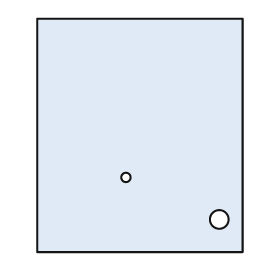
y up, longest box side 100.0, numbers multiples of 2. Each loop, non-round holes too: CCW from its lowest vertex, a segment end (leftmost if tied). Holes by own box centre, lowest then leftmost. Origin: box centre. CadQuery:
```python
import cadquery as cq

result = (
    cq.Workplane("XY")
    .moveTo(-44.0, -50.0)
    .lineTo(44.0, -50.0)
    .lineTo(44.0, 50.0)
    .lineTo(-44.0, 50.0)
    .close()
    .moveTo(34.0, -36.0)
    .circle(4.0)
    .moveTo(-6.0, -18.0)
    .circle(2.0)
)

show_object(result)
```